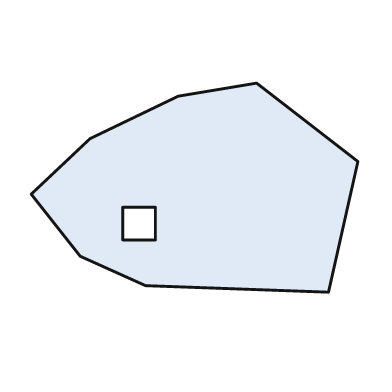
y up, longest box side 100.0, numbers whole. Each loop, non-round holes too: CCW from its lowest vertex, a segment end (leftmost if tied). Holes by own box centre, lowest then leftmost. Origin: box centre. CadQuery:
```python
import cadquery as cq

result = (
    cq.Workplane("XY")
    .moveTo(41.0, -32.0)
    .lineTo(50.0, 8.0)
    .lineTo(19.0, 32.0)
    .lineTo(-5.0, 28.0)
    .lineTo(-32.0, 15.0)
    .lineTo(-50.0, -2.0)
    .lineTo(-35.0, -21.0)
    .lineTo(-15.0, -30.0)
    .close()
    .moveTo(-22.0, -16.0)
    .lineTo(-12.0, -16.0)
    .lineTo(-12.0, -6.0)
    .lineTo(-22.0, -6.0)
    .close()
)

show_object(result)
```